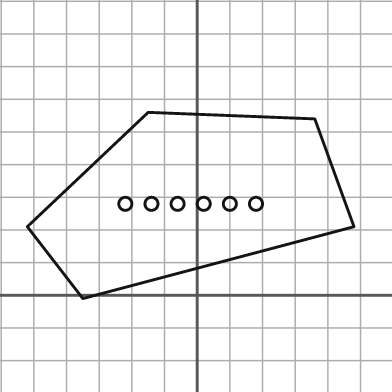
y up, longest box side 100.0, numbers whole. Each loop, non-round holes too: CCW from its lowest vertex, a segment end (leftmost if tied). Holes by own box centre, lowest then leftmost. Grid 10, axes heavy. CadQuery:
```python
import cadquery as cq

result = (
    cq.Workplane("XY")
    .moveTo(-35.0, -1.0)
    .lineTo(48.0, 21.0)
    .lineTo(36.0, 54.0)
    .lineTo(-15.0, 56.0)
    .lineTo(-52.0, 21.0)
    .close()
    .moveTo(-22.0, 28.0)
    .circle(2.0)
    .moveTo(-14.0, 28.0)
    .circle(2.0)
    .moveTo(-6.0, 28.0)
    .circle(2.0)
    .moveTo(2.0, 28.0)
    .circle(2.0)
    .moveTo(10.0, 28.0)
    .circle(2.0)
    .moveTo(18.0, 28.0)
    .circle(2.0)
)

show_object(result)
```